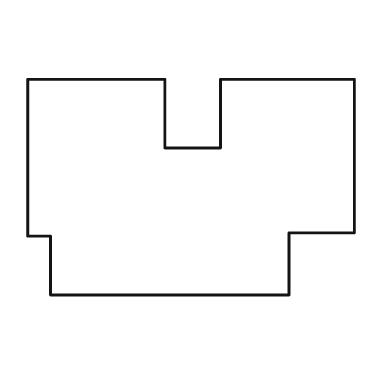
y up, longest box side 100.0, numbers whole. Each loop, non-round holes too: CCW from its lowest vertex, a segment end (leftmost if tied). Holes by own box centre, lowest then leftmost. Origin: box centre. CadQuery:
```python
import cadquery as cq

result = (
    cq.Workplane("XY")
    .moveTo(-43.0, -33.0)
    .lineTo(30.0, -33.0)
    .lineTo(30.0, -14.0)
    .lineTo(50.0, -14.0)
    .lineTo(50.0, 33.0)
    .lineTo(9.0, 33.0)
    .lineTo(9.0, 12.0)
    .lineTo(-8.0, 12.0)
    .lineTo(-8.0, 33.0)
    .lineTo(-50.0, 33.0)
    .lineTo(-50.0, -15.0)
    .lineTo(-43.0, -15.0)
    .close()
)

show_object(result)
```